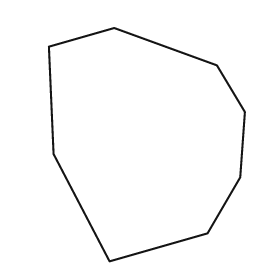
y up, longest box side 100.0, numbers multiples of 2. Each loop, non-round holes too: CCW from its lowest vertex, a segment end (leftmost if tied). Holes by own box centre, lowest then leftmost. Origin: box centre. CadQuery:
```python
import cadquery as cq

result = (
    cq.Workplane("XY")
    .moveTo(-16.0, -50.0)
    .lineTo(26.0, -38.0)
    .lineTo(40.0, -14.0)
    .lineTo(42.0, 14.0)
    .lineTo(30.0, 34.0)
    .lineTo(-14.0, 50.0)
    .lineTo(-42.0, 42.0)
    .lineTo(-40.0, -4.0)
    .close()
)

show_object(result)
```